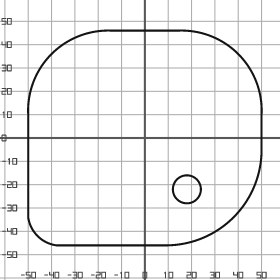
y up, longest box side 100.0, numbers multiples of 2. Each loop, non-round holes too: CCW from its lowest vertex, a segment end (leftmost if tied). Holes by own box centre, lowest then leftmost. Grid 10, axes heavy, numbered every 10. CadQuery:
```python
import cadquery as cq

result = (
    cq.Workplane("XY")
    .moveTo(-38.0, -46.0)
    .lineTo(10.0, -46.0)
    .threePointArc((38.0, -34.0), (50.0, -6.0))
    .lineTo(50.0, 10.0)
    .threePointArc((40.0, 36.0), (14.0, 46.0))
    .lineTo(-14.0, 46.0)
    .threePointArc((-40.0, 36.0), (-50.0, 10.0))
    .lineTo(-50.0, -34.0)
    .threePointArc((-46.0, -42.0), (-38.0, -46.0))
    .close()
    .moveTo(18.0, -22.0)
    .circle(6.0)
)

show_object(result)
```